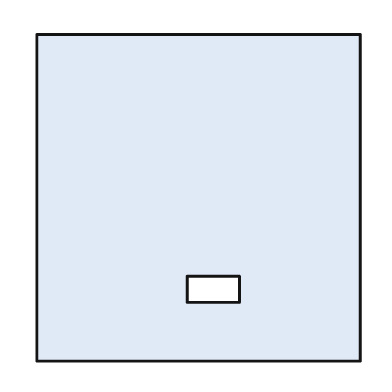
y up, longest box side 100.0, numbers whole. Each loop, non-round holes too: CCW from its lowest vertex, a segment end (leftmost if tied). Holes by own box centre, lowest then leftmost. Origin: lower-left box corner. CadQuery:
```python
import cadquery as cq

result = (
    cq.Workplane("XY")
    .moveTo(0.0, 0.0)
    .lineTo(99.0, 0.0)
    .lineTo(99.0, 100.0)
    .lineTo(0.0, 100.0)
    .close()
    .moveTo(46.0, 18.0)
    .lineTo(62.0, 18.0)
    .lineTo(62.0, 26.0)
    .lineTo(46.0, 26.0)
    .close()
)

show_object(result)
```